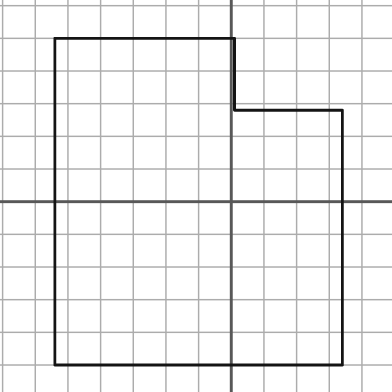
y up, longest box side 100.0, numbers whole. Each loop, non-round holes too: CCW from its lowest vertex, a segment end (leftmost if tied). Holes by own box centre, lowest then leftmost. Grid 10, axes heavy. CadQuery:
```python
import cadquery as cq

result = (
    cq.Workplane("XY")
    .moveTo(-54.0, -50.0)
    .lineTo(34.0, -50.0)
    .lineTo(34.0, 28.0)
    .lineTo(1.0, 28.0)
    .lineTo(1.0, 50.0)
    .lineTo(-54.0, 50.0)
    .close()
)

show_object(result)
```